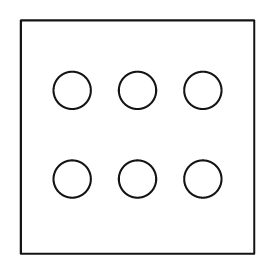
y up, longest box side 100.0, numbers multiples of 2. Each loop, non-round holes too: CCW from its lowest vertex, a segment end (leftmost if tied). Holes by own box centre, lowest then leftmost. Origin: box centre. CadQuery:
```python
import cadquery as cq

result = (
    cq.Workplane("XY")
    .moveTo(-50.0, -50.0)
    .lineTo(50.0, -50.0)
    .lineTo(50.0, 50.0)
    .lineTo(-50.0, 50.0)
    .close()
    .moveTo(-28.0, -18.0)
    .circle(8.0)
    .moveTo(0.0, -18.0)
    .circle(8.0)
    .moveTo(28.0, -18.0)
    .circle(8.0)
    .moveTo(-28.0, 20.0)
    .circle(8.0)
    .moveTo(0.0, 20.0)
    .circle(8.0)
    .moveTo(28.0, 20.0)
    .circle(8.0)
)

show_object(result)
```